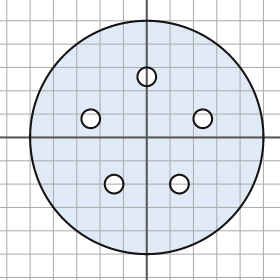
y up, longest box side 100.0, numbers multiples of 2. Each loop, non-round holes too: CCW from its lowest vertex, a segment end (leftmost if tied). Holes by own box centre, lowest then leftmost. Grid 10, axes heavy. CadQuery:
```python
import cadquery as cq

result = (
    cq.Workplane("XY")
    .moveTo(0.0, 0.0)
    .circle(50.0)
    .moveTo(-14.0, -20.0)
    .circle(4.0)
    .moveTo(14.0, -20.0)
    .circle(4.0)
    .moveTo(-24.0, 8.0)
    .circle(4.0)
    .moveTo(24.0, 8.0)
    .circle(4.0)
    .moveTo(0.0, 26.0)
    .circle(4.0)
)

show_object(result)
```